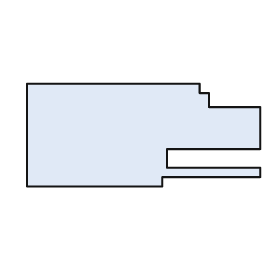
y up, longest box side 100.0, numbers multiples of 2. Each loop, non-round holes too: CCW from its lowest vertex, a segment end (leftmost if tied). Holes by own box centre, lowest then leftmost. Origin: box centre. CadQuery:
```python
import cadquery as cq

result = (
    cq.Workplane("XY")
    .moveTo(-50.0, -22.0)
    .lineTo(8.0, -22.0)
    .lineTo(8.0, -18.0)
    .lineTo(50.0, -18.0)
    .lineTo(50.0, -14.0)
    .lineTo(10.0, -14.0)
    .lineTo(10.0, -6.0)
    .lineTo(50.0, -6.0)
    .lineTo(50.0, 12.0)
    .lineTo(28.0, 12.0)
    .lineTo(28.0, 18.0)
    .lineTo(24.0, 18.0)
    .lineTo(24.0, 22.0)
    .lineTo(-50.0, 22.0)
    .close()
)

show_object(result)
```